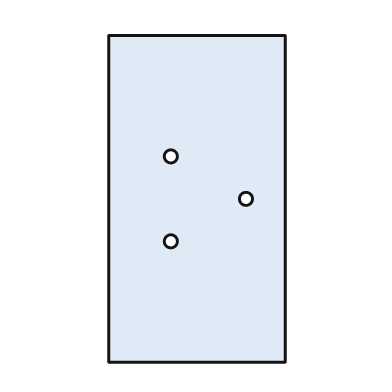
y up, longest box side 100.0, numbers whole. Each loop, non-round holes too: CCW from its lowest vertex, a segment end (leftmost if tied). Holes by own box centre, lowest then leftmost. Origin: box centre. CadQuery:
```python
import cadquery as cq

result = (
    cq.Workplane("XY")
    .moveTo(-27.0, -50.0)
    .lineTo(27.0, -50.0)
    .lineTo(27.0, 50.0)
    .lineTo(-27.0, 50.0)
    .close()
    .moveTo(-8.0, -13.0)
    .circle(2.0)
    .moveTo(15.0, 0.0)
    .circle(2.0)
    .moveTo(-8.0, 13.0)
    .circle(2.0)
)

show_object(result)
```